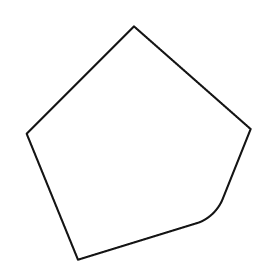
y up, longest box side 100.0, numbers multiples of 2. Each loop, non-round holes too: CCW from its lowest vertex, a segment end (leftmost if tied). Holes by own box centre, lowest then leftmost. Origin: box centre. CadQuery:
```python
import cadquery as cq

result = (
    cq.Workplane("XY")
    .moveTo(-26.0, -50.0)
    .lineTo(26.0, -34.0)
    .threePointArc((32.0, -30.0), (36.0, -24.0))
    .lineTo(48.0, 6.0)
    .lineTo(-2.0, 50.0)
    .lineTo(-48.0, 4.0)
    .close()
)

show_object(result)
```